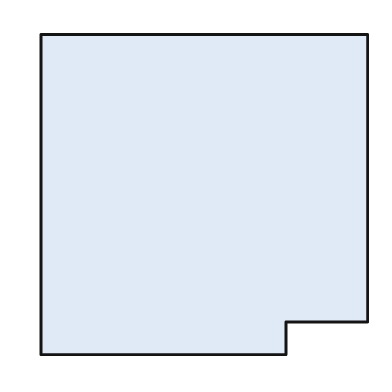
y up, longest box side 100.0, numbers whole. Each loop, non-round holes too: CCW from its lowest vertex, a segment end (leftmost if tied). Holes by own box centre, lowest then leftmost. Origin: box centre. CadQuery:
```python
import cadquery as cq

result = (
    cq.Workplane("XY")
    .moveTo(-50.0, -49.0)
    .lineTo(25.0, -49.0)
    .lineTo(25.0, -39.0)
    .lineTo(50.0, -39.0)
    .lineTo(50.0, 49.0)
    .lineTo(-50.0, 49.0)
    .close()
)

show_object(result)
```